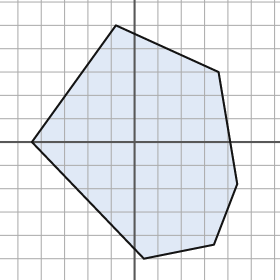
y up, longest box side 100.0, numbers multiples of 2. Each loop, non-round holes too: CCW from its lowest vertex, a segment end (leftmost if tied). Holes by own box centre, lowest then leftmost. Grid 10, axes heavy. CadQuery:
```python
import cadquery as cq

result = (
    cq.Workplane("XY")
    .moveTo(4.0, -50.0)
    .lineTo(34.0, -44.0)
    .lineTo(44.0, -18.0)
    .lineTo(36.0, 30.0)
    .lineTo(-8.0, 50.0)
    .lineTo(-44.0, 0.0)
    .close()
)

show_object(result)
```